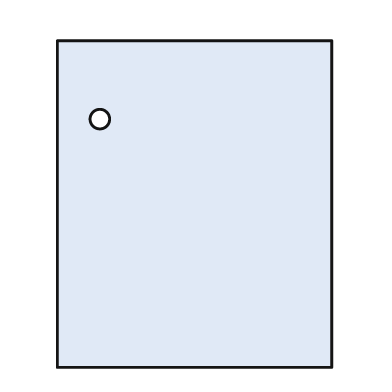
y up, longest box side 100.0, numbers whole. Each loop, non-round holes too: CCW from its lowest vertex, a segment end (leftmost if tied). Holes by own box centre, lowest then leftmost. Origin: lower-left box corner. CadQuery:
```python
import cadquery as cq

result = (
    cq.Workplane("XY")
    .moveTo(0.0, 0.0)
    .lineTo(84.0, 0.0)
    .lineTo(84.0, 100.0)
    .lineTo(0.0, 100.0)
    .close()
    .moveTo(13.0, 76.0)
    .circle(3.0)
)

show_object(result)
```